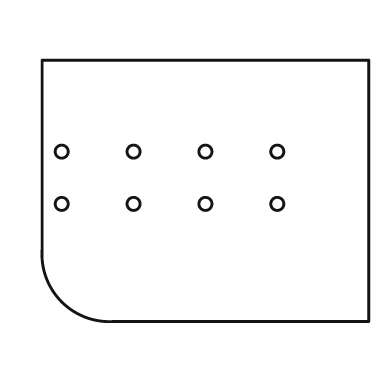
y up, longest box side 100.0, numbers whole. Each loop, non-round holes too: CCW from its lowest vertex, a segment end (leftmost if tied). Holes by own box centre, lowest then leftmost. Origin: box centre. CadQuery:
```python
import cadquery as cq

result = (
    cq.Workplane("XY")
    .moveTo(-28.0, -40.0)
    .lineTo(50.0, -40.0)
    .lineTo(50.0, 40.0)
    .lineTo(-50.0, 40.0)
    .lineTo(-50.0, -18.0)
    .threePointArc((-44.0, -34.0), (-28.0, -40.0))
    .close()
    .moveTo(-44.0, -4.0)
    .circle(2.0)
    .moveTo(-22.0, -4.0)
    .circle(2.0)
    .moveTo(0.0, -4.0)
    .circle(2.0)
    .moveTo(22.0, -4.0)
    .circle(2.0)
    .moveTo(-44.0, 12.0)
    .circle(2.0)
    .moveTo(-22.0, 12.0)
    .circle(2.0)
    .moveTo(0.0, 12.0)
    .circle(2.0)
    .moveTo(22.0, 12.0)
    .circle(2.0)
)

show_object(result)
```